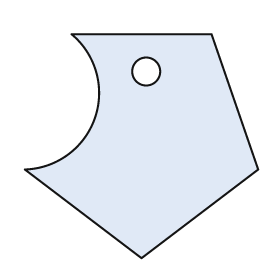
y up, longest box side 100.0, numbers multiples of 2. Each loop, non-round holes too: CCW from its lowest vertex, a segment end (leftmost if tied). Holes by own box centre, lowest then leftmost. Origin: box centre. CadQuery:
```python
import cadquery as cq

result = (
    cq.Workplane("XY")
    .moveTo(0.0, -48.0)
    .lineTo(50.0, -10.0)
    .lineTo(30.0, 48.0)
    .lineTo(-30.0, 48.0)
    .threePointArc((-20.0, 12.0), (-50.0, -10.0))
    .close()
    .moveTo(2.0, 32.0)
    .circle(6.0)
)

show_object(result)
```